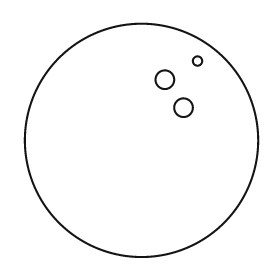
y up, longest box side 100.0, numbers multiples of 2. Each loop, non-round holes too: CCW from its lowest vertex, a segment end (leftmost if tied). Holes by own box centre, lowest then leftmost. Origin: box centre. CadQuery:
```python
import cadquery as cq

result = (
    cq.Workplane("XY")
    .moveTo(0.0, 0.0)
    .circle(50.0)
    .moveTo(18.0, 14.0)
    .circle(4.0)
    .moveTo(10.0, 26.0)
    .circle(4.0)
    .moveTo(24.0, 34.0)
    .circle(2.0)
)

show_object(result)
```